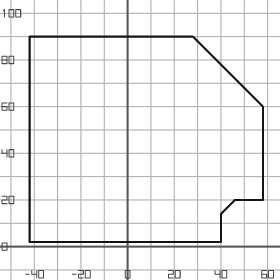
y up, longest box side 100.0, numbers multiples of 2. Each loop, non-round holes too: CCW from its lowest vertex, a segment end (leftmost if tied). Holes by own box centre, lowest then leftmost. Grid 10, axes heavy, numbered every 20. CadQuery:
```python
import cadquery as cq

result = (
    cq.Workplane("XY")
    .moveTo(-42.0, 2.0)
    .lineTo(40.0, 2.0)
    .lineTo(40.0, 14.0)
    .lineTo(46.0, 20.0)
    .lineTo(58.0, 20.0)
    .lineTo(58.0, 60.0)
    .lineTo(28.0, 90.0)
    .lineTo(-42.0, 90.0)
    .close()
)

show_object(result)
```